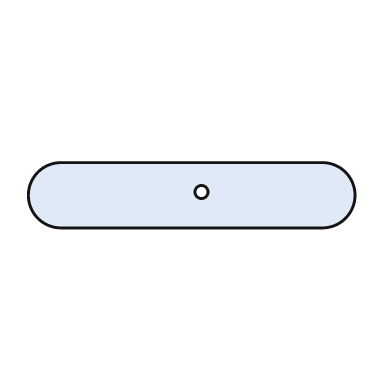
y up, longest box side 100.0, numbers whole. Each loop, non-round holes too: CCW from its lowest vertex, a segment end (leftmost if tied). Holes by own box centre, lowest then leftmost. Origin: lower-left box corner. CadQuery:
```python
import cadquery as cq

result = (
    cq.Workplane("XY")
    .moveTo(10.0, 0.0)
    .lineTo(90.0, 0.0)
    .threePointArc((100.0, 10.0), (90.0, 20.0))
    .lineTo(10.0, 20.0)
    .threePointArc((0.0, 10.0), (10.0, 0.0))
    .close()
    .moveTo(53.0, 11.0)
    .circle(2.0)
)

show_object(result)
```